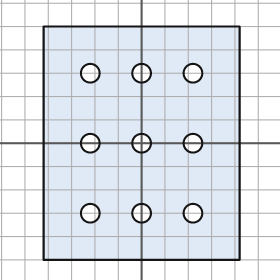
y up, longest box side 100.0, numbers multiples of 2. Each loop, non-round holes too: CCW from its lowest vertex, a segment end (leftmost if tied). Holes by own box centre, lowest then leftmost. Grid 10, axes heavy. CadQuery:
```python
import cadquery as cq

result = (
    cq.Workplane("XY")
    .moveTo(-42.0, -50.0)
    .lineTo(42.0, -50.0)
    .lineTo(42.0, 50.0)
    .lineTo(-42.0, 50.0)
    .close()
    .moveTo(-22.0, -30.0)
    .circle(4.0)
    .moveTo(0.0, -30.0)
    .circle(4.0)
    .moveTo(22.0, -30.0)
    .circle(4.0)
    .moveTo(-22.0, 0.0)
    .circle(4.0)
    .moveTo(0.0, 0.0)
    .circle(4.0)
    .moveTo(22.0, 0.0)
    .circle(4.0)
    .moveTo(-22.0, 30.0)
    .circle(4.0)
    .moveTo(0.0, 30.0)
    .circle(4.0)
    .moveTo(22.0, 30.0)
    .circle(4.0)
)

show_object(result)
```